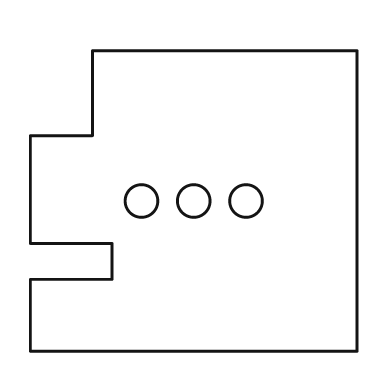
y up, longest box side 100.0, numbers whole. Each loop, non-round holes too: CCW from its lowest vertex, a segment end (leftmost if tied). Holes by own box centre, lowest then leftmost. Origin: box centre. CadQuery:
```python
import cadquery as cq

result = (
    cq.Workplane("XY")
    .moveTo(-50.0, -46.0)
    .lineTo(50.0, -46.0)
    .lineTo(50.0, 46.0)
    .lineTo(-31.0, 46.0)
    .lineTo(-31.0, 20.0)
    .lineTo(-50.0, 20.0)
    .lineTo(-50.0, -13.0)
    .lineTo(-25.0, -13.0)
    .lineTo(-25.0, -24.0)
    .lineTo(-50.0, -24.0)
    .close()
    .moveTo(-16.0, 0.0)
    .circle(5.0)
    .moveTo(0.0, 0.0)
    .circle(5.0)
    .moveTo(16.0, 0.0)
    .circle(5.0)
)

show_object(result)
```